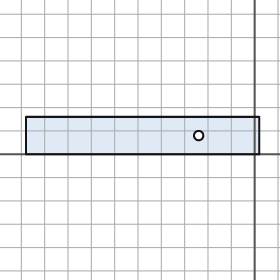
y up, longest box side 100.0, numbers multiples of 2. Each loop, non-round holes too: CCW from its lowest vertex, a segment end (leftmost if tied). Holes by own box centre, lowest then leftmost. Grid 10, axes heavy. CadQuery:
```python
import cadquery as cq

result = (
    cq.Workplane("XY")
    .moveTo(-98.0, 0.0)
    .lineTo(2.0, 0.0)
    .lineTo(2.0, 16.0)
    .lineTo(-98.0, 16.0)
    .close()
    .moveTo(-24.0, 8.0)
    .circle(2.0)
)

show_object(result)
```